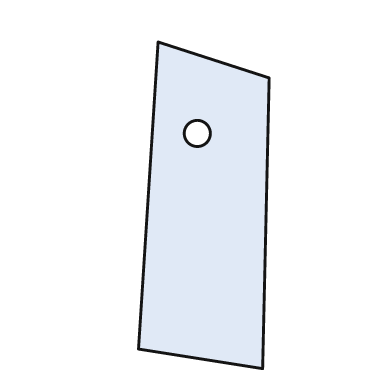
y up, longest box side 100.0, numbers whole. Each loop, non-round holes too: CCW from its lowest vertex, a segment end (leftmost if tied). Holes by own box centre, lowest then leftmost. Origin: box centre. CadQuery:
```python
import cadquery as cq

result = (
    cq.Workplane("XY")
    .moveTo(18.0, -50.0)
    .lineTo(20.0, 39.0)
    .lineTo(-14.0, 50.0)
    .lineTo(-20.0, -44.0)
    .close()
    .moveTo(-2.0, 22.0)
    .circle(4.0)
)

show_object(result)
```